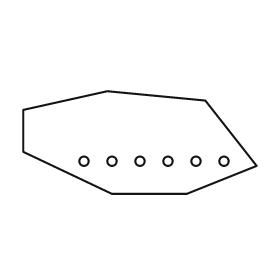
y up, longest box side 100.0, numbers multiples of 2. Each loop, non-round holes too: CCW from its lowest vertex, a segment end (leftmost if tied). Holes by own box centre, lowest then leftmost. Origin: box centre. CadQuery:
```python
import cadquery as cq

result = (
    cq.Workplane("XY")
    .moveTo(-12.0, -22.0)
    .lineTo(20.0, -22.0)
    .lineTo(50.0, -10.0)
    .lineTo(28.0, 18.0)
    .lineTo(-14.0, 22.0)
    .lineTo(-50.0, 14.0)
    .lineTo(-50.0, -4.0)
    .close()
    .moveTo(-24.0, -8.0)
    .circle(2.0)
    .moveTo(-12.0, -8.0)
    .circle(2.0)
    .moveTo(0.0, -8.0)
    .circle(2.0)
    .moveTo(12.0, -8.0)
    .circle(2.0)
    .moveTo(24.0, -8.0)
    .circle(2.0)
    .moveTo(36.0, -8.0)
    .circle(2.0)
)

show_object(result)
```